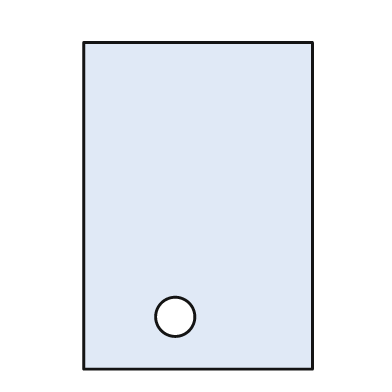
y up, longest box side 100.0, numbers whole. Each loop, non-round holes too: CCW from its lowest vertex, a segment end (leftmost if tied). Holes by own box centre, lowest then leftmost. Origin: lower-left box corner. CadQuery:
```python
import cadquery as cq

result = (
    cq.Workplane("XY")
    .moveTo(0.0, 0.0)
    .lineTo(70.0, 0.0)
    .lineTo(70.0, 100.0)
    .lineTo(0.0, 100.0)
    .close()
    .moveTo(28.0, 16.0)
    .circle(6.0)
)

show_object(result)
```